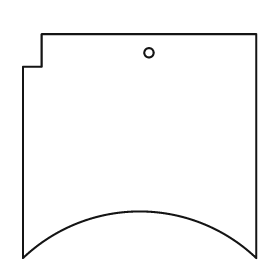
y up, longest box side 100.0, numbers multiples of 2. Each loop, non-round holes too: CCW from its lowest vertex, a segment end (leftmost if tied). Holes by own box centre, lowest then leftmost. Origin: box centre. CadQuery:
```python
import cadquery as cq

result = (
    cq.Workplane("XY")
    .moveTo(-50.0, -48.0)
    .threePointArc((0.0, -28.0), (50.0, -48.0))
    .lineTo(50.0, 48.0)
    .lineTo(-42.0, 48.0)
    .lineTo(-42.0, 34.0)
    .lineTo(-50.0, 34.0)
    .close()
    .moveTo(4.0, 40.0)
    .circle(2.0)
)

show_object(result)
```